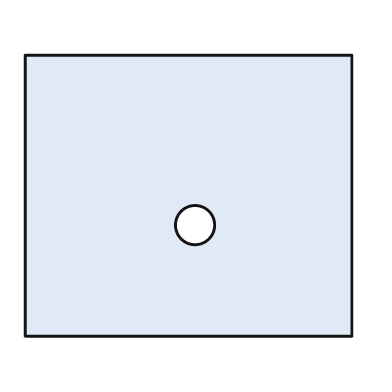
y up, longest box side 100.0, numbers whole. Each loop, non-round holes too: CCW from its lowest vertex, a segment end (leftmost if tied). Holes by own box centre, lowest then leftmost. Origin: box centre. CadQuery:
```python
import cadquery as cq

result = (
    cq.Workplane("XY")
    .moveTo(-50.0, -43.0)
    .lineTo(50.0, -43.0)
    .lineTo(50.0, 43.0)
    .lineTo(-50.0, 43.0)
    .close()
    .moveTo(2.0, -9.0)
    .circle(6.0)
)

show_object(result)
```